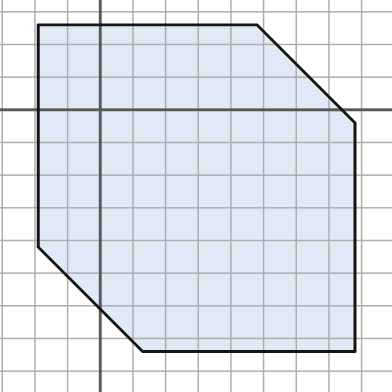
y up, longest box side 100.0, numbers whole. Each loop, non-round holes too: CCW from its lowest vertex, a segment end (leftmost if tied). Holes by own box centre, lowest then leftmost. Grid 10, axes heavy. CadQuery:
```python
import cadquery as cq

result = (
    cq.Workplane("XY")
    .moveTo(13.0, -74.0)
    .lineTo(78.0, -74.0)
    .lineTo(78.0, -4.0)
    .lineTo(48.0, 26.0)
    .lineTo(-19.0, 26.0)
    .lineTo(-19.0, -42.0)
    .close()
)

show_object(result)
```